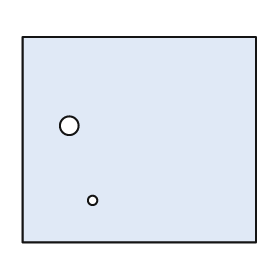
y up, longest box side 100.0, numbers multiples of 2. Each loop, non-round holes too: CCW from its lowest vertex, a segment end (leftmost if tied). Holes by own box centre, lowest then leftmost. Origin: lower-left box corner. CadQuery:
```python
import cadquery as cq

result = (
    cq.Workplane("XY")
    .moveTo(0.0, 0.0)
    .lineTo(100.0, 0.0)
    .lineTo(100.0, 88.0)
    .lineTo(0.0, 88.0)
    .close()
    .moveTo(30.0, 18.0)
    .circle(2.0)
    .moveTo(20.0, 50.0)
    .circle(4.0)
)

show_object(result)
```